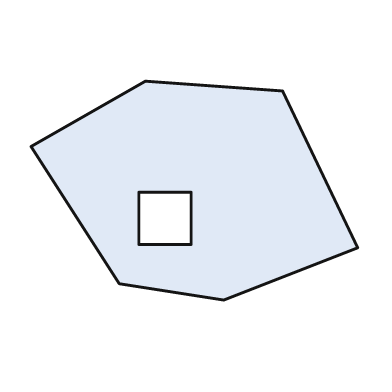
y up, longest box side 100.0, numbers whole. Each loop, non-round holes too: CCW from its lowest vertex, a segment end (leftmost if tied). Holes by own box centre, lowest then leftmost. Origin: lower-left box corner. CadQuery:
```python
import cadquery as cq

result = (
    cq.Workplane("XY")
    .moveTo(59.0, 0.0)
    .lineTo(100.0, 16.0)
    .lineTo(77.0, 64.0)
    .lineTo(35.0, 67.0)
    .lineTo(0.0, 47.0)
    .lineTo(27.0, 5.0)
    .close()
    .moveTo(33.0, 17.0)
    .lineTo(49.0, 17.0)
    .lineTo(49.0, 33.0)
    .lineTo(33.0, 33.0)
    .close()
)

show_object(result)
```